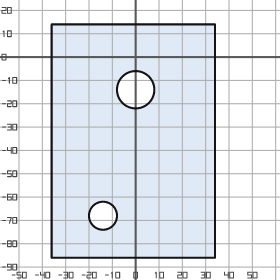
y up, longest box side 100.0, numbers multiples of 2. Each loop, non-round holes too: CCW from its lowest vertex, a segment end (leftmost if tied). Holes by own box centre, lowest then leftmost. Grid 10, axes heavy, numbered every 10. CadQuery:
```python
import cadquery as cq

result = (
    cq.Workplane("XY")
    .moveTo(-36.0, -86.0)
    .lineTo(34.0, -86.0)
    .lineTo(34.0, 14.0)
    .lineTo(-36.0, 14.0)
    .close()
    .moveTo(-14.0, -68.0)
    .circle(6.0)
    .moveTo(0.0, -14.0)
    .circle(8.0)
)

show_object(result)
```